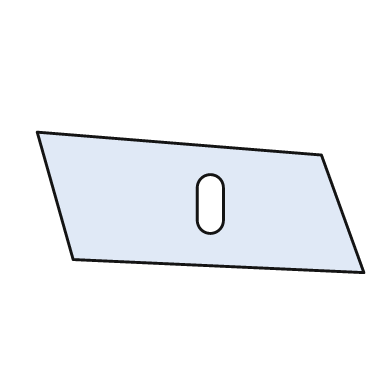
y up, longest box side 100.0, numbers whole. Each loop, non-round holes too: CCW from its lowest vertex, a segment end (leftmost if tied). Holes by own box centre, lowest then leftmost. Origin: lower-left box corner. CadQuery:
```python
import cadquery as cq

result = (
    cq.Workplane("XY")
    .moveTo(100.0, 0.0)
    .lineTo(87.0, 36.0)
    .lineTo(0.0, 43.0)
    .lineTo(11.0, 4.0)
    .close()
    .moveTo(49.0, 16.0)
    .threePointArc((53.0, 12.0), (57.0, 16.0))
    .lineTo(57.0, 26.0)
    .threePointArc((53.0, 30.0), (49.0, 26.0))
    .close()
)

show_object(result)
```